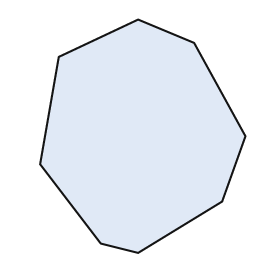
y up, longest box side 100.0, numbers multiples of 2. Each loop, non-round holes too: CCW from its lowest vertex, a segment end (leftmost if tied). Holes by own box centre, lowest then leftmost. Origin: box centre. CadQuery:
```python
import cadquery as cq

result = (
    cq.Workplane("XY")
    .moveTo(-2.0, -50.0)
    .lineTo(34.0, -28.0)
    .lineTo(44.0, 0.0)
    .lineTo(22.0, 40.0)
    .lineTo(-2.0, 50.0)
    .lineTo(-36.0, 34.0)
    .lineTo(-44.0, -12.0)
    .lineTo(-18.0, -46.0)
    .close()
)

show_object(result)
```